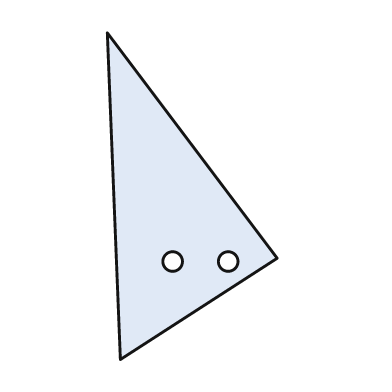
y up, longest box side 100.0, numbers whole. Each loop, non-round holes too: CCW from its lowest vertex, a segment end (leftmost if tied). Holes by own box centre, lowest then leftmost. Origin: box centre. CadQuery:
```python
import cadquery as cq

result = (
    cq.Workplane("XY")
    .moveTo(-22.0, -50.0)
    .lineTo(26.0, -19.0)
    .lineTo(-26.0, 50.0)
    .close()
    .moveTo(-6.0, -20.0)
    .circle(3.0)
    .moveTo(11.0, -20.0)
    .circle(3.0)
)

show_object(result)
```